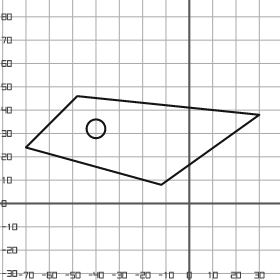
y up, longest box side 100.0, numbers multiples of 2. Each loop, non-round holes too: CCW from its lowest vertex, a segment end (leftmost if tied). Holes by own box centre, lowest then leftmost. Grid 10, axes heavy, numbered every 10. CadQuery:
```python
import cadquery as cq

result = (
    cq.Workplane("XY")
    .moveTo(-12.0, 8.0)
    .lineTo(30.0, 38.0)
    .lineTo(-48.0, 46.0)
    .lineTo(-70.0, 24.0)
    .close()
    .moveTo(-40.0, 32.0)
    .circle(4.0)
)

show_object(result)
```